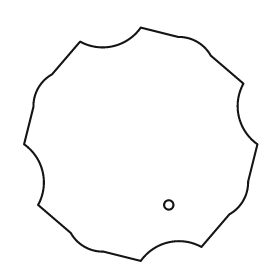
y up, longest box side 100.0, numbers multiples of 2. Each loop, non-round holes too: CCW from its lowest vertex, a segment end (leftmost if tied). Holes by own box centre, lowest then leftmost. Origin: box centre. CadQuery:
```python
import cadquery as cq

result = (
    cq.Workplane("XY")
    .moveTo(0.0, -50.0)
    .threePointArc((12.0, -42.0), (26.0, -44.0))
    .lineTo(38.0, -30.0)
    .threePointArc((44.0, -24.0), (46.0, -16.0))
    .lineTo(50.0, 0.0)
    .threePointArc((42.0, 12.0), (44.0, 26.0))
    .lineTo(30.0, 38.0)
    .threePointArc((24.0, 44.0), (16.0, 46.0))
    .lineTo(0.0, 50.0)
    .threePointArc((-12.0, 42.0), (-26.0, 44.0))
    .lineTo(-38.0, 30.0)
    .threePointArc((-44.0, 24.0), (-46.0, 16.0))
    .lineTo(-50.0, 0.0)
    .threePointArc((-42.0, -12.0), (-44.0, -26.0))
    .lineTo(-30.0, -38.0)
    .threePointArc((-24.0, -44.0), (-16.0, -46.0))
    .close()
    .moveTo(12.0, -26.0)
    .circle(2.0)
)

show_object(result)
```